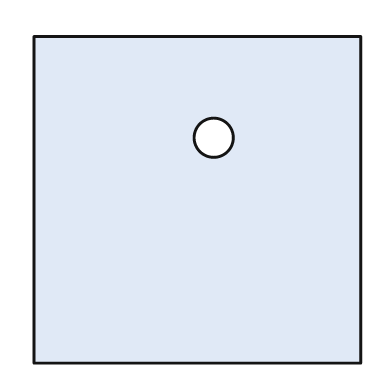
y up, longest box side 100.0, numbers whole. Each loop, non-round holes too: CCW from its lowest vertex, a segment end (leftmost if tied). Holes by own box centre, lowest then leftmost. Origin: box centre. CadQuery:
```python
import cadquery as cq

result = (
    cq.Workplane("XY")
    .moveTo(-50.0, -50.0)
    .lineTo(50.0, -50.0)
    .lineTo(50.0, 50.0)
    .lineTo(-50.0, 50.0)
    .close()
    .moveTo(5.0, 19.0)
    .circle(6.0)
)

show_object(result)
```